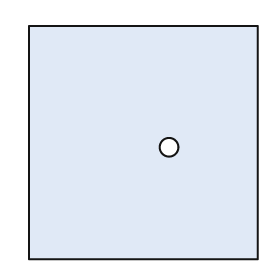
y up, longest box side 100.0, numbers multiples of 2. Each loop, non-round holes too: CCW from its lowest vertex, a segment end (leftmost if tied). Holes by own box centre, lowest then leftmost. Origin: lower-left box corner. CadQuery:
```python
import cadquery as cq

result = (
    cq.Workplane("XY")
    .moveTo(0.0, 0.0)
    .lineTo(98.0, 0.0)
    .lineTo(98.0, 100.0)
    .lineTo(0.0, 100.0)
    .close()
    .moveTo(60.0, 48.0)
    .circle(4.0)
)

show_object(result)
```